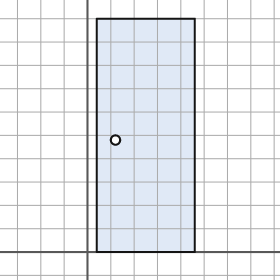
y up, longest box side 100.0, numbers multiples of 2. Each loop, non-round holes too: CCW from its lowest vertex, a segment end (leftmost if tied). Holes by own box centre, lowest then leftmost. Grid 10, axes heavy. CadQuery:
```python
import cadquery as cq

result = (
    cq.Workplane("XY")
    .moveTo(4.0, 0.0)
    .lineTo(46.0, 0.0)
    .lineTo(46.0, 100.0)
    .lineTo(4.0, 100.0)
    .close()
    .moveTo(12.0, 48.0)
    .circle(2.0)
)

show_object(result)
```